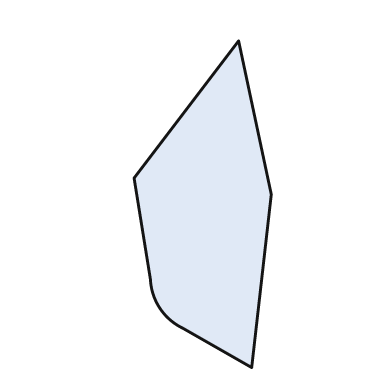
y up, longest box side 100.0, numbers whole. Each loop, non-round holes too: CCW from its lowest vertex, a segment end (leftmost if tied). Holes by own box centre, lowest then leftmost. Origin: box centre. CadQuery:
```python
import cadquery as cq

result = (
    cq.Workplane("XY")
    .moveTo(15.0, -50.0)
    .lineTo(21.0, 3.0)
    .lineTo(11.0, 50.0)
    .lineTo(-21.0, 8.0)
    .lineTo(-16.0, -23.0)
    .threePointArc((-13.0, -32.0), (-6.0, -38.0))
    .close()
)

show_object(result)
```